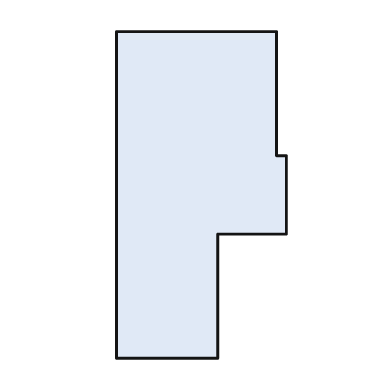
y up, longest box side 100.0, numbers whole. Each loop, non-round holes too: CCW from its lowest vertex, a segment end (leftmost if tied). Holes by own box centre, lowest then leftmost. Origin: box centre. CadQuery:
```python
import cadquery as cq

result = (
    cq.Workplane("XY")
    .moveTo(-26.0, -50.0)
    .lineTo(5.0, -50.0)
    .lineTo(5.0, -12.0)
    .lineTo(26.0, -12.0)
    .lineTo(26.0, 12.0)
    .lineTo(23.0, 12.0)
    .lineTo(23.0, 50.0)
    .lineTo(-26.0, 50.0)
    .close()
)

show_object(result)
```